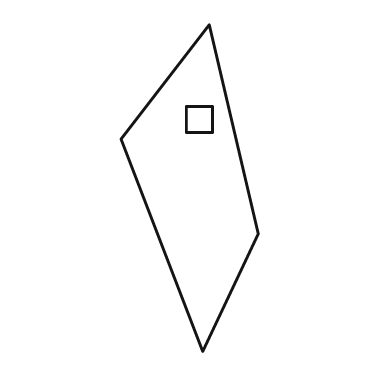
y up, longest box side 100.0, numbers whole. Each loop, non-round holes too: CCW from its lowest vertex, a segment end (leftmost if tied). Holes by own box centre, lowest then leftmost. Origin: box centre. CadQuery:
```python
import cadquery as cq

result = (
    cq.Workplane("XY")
    .moveTo(4.0, -50.0)
    .lineTo(21.0, -14.0)
    .lineTo(6.0, 50.0)
    .lineTo(-21.0, 15.0)
    .close()
    .moveTo(-1.0, 17.0)
    .lineTo(7.0, 17.0)
    .lineTo(7.0, 25.0)
    .lineTo(-1.0, 25.0)
    .close()
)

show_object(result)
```